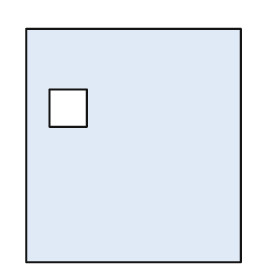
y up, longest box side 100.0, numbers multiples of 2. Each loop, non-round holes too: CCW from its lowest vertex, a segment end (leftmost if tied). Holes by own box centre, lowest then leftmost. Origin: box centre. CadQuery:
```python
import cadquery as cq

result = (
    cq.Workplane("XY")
    .moveTo(-46.0, -50.0)
    .lineTo(46.0, -50.0)
    .lineTo(46.0, 50.0)
    .lineTo(-46.0, 50.0)
    .close()
    .moveTo(-36.0, 8.0)
    .lineTo(-20.0, 8.0)
    .lineTo(-20.0, 24.0)
    .lineTo(-36.0, 24.0)
    .close()
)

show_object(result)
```